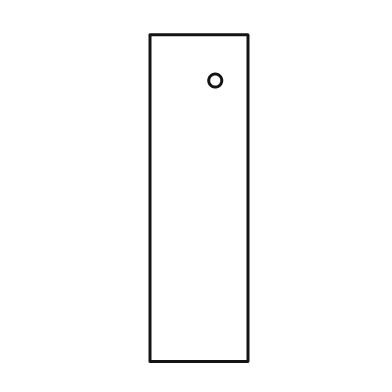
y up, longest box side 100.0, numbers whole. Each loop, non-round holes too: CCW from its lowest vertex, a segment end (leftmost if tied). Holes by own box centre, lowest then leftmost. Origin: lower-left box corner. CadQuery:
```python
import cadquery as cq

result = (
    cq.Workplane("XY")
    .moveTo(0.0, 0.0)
    .lineTo(30.0, 0.0)
    .lineTo(30.0, 100.0)
    .lineTo(0.0, 100.0)
    .close()
    .moveTo(20.0, 86.0)
    .circle(2.0)
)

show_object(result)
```